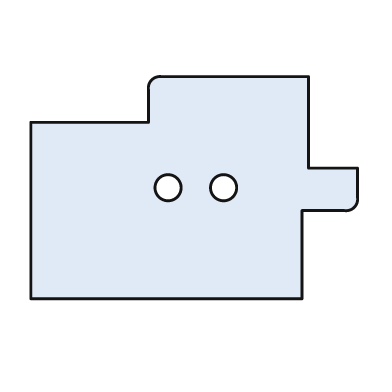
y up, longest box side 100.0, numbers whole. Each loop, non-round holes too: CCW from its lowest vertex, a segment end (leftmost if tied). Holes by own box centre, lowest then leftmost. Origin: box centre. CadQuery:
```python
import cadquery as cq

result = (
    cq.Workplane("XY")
    .moveTo(-50.0, -34.0)
    .lineTo(33.0, -34.0)
    .lineTo(33.0, -7.0)
    .lineTo(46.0, -7.0)
    .threePointArc((49.0, -6.0), (50.0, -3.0))
    .lineTo(50.0, 6.0)
    .lineTo(35.0, 6.0)
    .lineTo(35.0, 34.0)
    .lineTo(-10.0, 34.0)
    .threePointArc((-13.0, 33.0), (-14.0, 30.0))
    .lineTo(-14.0, 20.0)
    .lineTo(-50.0, 20.0)
    .close()
    .moveTo(-8.0, 0.0)
    .circle(4.0)
    .moveTo(9.0, 0.0)
    .circle(4.0)
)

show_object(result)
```